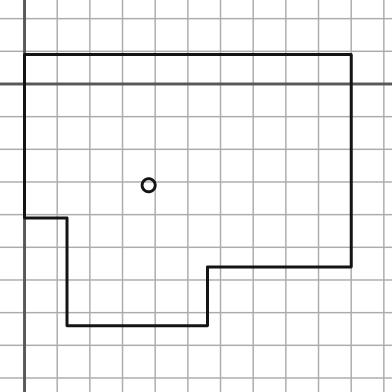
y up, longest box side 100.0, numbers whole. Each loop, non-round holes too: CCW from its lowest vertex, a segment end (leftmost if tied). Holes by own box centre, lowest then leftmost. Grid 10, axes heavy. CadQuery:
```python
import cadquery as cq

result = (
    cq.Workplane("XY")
    .moveTo(13.0, -74.0)
    .lineTo(56.0, -74.0)
    .lineTo(56.0, -56.0)
    .lineTo(100.0, -56.0)
    .lineTo(100.0, 9.0)
    .lineTo(0.0, 9.0)
    .lineTo(0.0, -41.0)
    .lineTo(13.0, -41.0)
    .close()
    .moveTo(38.0, -31.0)
    .circle(2.0)
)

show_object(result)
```